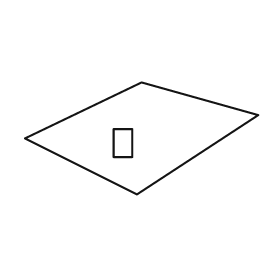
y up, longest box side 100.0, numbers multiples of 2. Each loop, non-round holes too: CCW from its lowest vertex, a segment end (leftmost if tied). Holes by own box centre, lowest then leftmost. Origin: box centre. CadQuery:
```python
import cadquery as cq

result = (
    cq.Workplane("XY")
    .moveTo(-2.0, -24.0)
    .lineTo(50.0, 10.0)
    .lineTo(0.0, 24.0)
    .lineTo(-50.0, 0.0)
    .close()
    .moveTo(-12.0, -8.0)
    .lineTo(-4.0, -8.0)
    .lineTo(-4.0, 4.0)
    .lineTo(-12.0, 4.0)
    .close()
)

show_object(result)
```